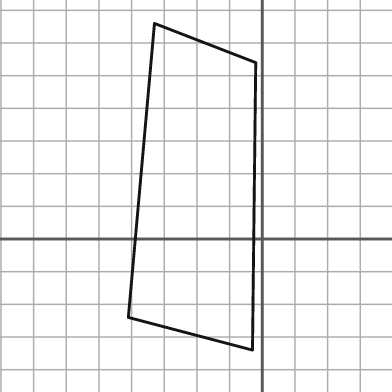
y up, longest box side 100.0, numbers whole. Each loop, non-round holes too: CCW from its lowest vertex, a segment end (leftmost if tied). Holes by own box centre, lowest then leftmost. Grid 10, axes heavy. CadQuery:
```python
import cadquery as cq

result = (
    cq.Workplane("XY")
    .moveTo(-3.0, -34.0)
    .lineTo(-2.0, 54.0)
    .lineTo(-33.0, 66.0)
    .lineTo(-41.0, -24.0)
    .close()
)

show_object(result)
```